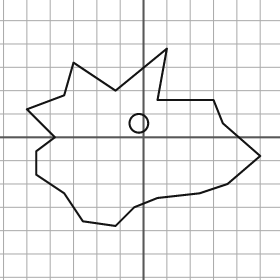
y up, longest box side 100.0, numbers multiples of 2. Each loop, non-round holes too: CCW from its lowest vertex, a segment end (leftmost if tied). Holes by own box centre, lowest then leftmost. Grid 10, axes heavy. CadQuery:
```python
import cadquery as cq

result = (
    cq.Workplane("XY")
    .moveTo(-12.0, -38.0)
    .lineTo(-4.0, -30.0)
    .lineTo(6.0, -26.0)
    .lineTo(24.0, -24.0)
    .lineTo(36.0, -20.0)
    .lineTo(50.0, -8.0)
    .lineTo(34.0, 6.0)
    .lineTo(30.0, 16.0)
    .lineTo(6.0, 16.0)
    .lineTo(10.0, 38.0)
    .lineTo(-12.0, 20.0)
    .lineTo(-30.0, 32.0)
    .lineTo(-34.0, 18.0)
    .lineTo(-50.0, 12.0)
    .lineTo(-38.0, 0.0)
    .lineTo(-46.0, -6.0)
    .lineTo(-46.0, -16.0)
    .lineTo(-34.0, -24.0)
    .lineTo(-26.0, -36.0)
    .close()
    .moveTo(-2.0, 6.0)
    .circle(4.0)
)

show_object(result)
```